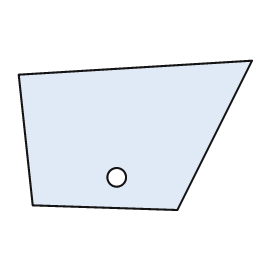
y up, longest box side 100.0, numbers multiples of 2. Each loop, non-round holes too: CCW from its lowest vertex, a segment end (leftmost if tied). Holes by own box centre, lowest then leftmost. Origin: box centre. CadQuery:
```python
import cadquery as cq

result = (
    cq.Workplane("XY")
    .moveTo(18.0, -32.0)
    .lineTo(50.0, 32.0)
    .lineTo(-50.0, 26.0)
    .lineTo(-44.0, -30.0)
    .close()
    .moveTo(-8.0, -18.0)
    .circle(4.0)
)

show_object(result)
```